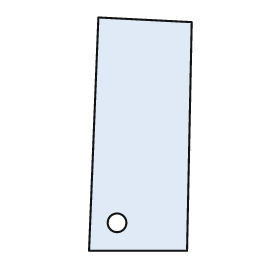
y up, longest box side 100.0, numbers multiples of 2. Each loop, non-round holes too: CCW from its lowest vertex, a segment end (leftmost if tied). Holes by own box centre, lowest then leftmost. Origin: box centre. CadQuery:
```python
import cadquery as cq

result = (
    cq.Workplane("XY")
    .moveTo(-22.0, -50.0)
    .lineTo(20.0, -50.0)
    .lineTo(22.0, 48.0)
    .lineTo(-18.0, 50.0)
    .close()
    .moveTo(-10.0, -38.0)
    .circle(4.0)
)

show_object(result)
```